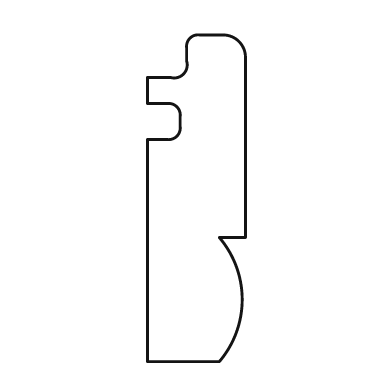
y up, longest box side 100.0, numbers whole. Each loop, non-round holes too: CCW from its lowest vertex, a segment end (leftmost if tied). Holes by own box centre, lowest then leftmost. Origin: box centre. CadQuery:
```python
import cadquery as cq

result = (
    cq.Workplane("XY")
    .moveTo(-15.0, -50.0)
    .lineTo(7.0, -50.0)
    .threePointArc((14.0, -31.0), (7.0, -12.0))
    .lineTo(15.0, -12.0)
    .lineTo(15.0, 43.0)
    .threePointArc((13.0, 48.0), (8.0, 50.0))
    .lineTo(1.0, 50.0)
    .threePointArc((-2.0, 49.0), (-3.0, 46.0))
    .lineTo(-3.0, 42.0)
    .threePointArc((-4.0, 38.0), (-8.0, 37.0))
    .lineTo(-15.0, 37.0)
    .lineTo(-15.0, 29.0)
    .lineTo(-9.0, 29.0)
    .threePointArc((-6.0, 28.0), (-5.0, 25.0))
    .lineTo(-5.0, 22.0)
    .threePointArc((-6.0, 19.0), (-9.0, 18.0))
    .lineTo(-15.0, 18.0)
    .close()
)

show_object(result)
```